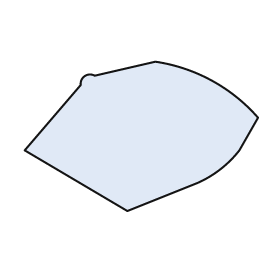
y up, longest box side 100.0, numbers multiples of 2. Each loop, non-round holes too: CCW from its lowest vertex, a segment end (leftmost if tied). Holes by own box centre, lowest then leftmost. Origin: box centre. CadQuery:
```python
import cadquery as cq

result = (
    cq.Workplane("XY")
    .moveTo(-6.0, -32.0)
    .lineTo(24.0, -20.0)
    .threePointArc((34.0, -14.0), (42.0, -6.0))
    .lineTo(50.0, 8.0)
    .threePointArc((30.0, 24.0), (6.0, 32.0))
    .lineTo(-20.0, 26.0)
    .threePointArc((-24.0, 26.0), (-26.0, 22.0))
    .lineTo(-50.0, -6.0)
    .close()
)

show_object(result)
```